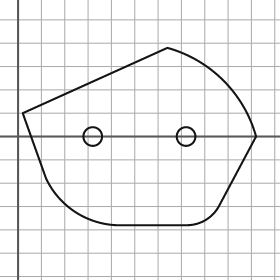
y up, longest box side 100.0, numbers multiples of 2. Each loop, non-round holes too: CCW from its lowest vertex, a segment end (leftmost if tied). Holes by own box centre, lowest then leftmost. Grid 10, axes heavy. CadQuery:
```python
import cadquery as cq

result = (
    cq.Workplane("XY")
    .moveTo(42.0, -38.0)
    .lineTo(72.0, -38.0)
    .threePointArc((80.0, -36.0), (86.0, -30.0))
    .lineTo(102.0, 0.0)
    .threePointArc((88.0, 24.0), (64.0, 38.0))
    .lineTo(2.0, 10.0)
    .lineTo(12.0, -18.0)
    .threePointArc((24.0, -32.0), (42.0, -38.0))
    .close()
    .moveTo(32.0, 0.0)
    .circle(4.0)
    .moveTo(72.0, 0.0)
    .circle(4.0)
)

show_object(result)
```